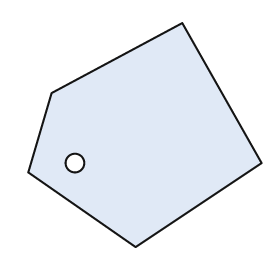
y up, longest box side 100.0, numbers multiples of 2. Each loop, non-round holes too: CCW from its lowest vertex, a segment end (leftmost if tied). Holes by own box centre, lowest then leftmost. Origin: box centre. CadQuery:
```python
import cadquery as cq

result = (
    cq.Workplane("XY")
    .moveTo(-4.0, -48.0)
    .lineTo(50.0, -12.0)
    .lineTo(16.0, 48.0)
    .lineTo(-40.0, 18.0)
    .lineTo(-50.0, -16.0)
    .close()
    .moveTo(-30.0, -12.0)
    .circle(4.0)
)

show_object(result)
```